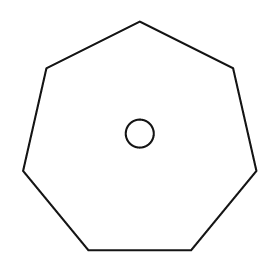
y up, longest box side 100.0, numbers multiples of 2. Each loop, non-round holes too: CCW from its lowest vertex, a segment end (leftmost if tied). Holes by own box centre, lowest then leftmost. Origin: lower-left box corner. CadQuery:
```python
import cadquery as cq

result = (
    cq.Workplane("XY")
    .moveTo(28.0, 0.0)
    .lineTo(72.0, 0.0)
    .lineTo(100.0, 34.0)
    .lineTo(90.0, 78.0)
    .lineTo(50.0, 98.0)
    .lineTo(10.0, 78.0)
    .lineTo(0.0, 34.0)
    .close()
    .moveTo(50.0, 50.0)
    .circle(6.0)
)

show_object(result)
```